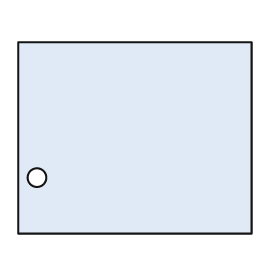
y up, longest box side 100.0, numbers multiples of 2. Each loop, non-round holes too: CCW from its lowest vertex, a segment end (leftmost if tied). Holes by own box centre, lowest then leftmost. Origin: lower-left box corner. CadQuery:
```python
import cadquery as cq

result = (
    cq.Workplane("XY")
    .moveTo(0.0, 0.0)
    .lineTo(100.0, 0.0)
    .lineTo(100.0, 82.0)
    .lineTo(0.0, 82.0)
    .close()
    .moveTo(8.0, 24.0)
    .circle(4.0)
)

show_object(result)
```